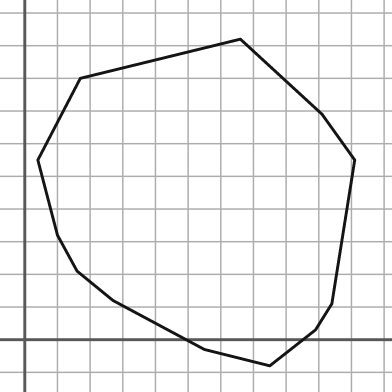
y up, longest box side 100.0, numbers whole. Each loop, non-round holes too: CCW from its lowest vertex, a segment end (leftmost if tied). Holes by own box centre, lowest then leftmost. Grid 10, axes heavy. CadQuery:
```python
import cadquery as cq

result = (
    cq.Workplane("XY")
    .moveTo(75.0, -8.0)
    .lineTo(89.0, 3.0)
    .lineTo(94.0, 11.0)
    .lineTo(101.0, 55.0)
    .lineTo(91.0, 69.0)
    .lineTo(66.0, 92.0)
    .lineTo(17.0, 80.0)
    .lineTo(4.0, 55.0)
    .lineTo(10.0, 32.0)
    .lineTo(16.0, 21.0)
    .lineTo(27.0, 12.0)
    .lineTo(55.0, -3.0)
    .close()
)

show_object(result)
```